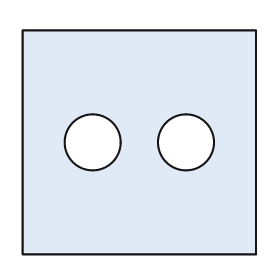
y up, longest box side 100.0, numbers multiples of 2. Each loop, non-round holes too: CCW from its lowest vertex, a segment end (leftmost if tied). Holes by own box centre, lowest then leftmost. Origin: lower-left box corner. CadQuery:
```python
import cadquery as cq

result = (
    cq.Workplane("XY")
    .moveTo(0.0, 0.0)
    .lineTo(100.0, 0.0)
    .lineTo(100.0, 96.0)
    .lineTo(0.0, 96.0)
    .close()
    .moveTo(30.0, 48.0)
    .circle(12.0)
    .moveTo(70.0, 48.0)
    .circle(12.0)
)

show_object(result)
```